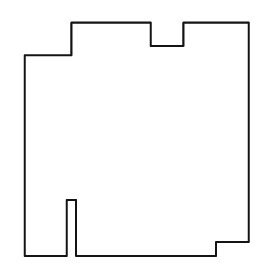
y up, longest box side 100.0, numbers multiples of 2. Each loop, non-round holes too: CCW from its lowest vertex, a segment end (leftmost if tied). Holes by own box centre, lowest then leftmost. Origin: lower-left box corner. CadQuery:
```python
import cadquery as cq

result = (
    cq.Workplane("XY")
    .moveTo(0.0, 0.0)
    .lineTo(18.0, 0.0)
    .lineTo(18.0, 24.0)
    .lineTo(22.0, 24.0)
    .lineTo(22.0, 0.0)
    .lineTo(82.0, 0.0)
    .lineTo(82.0, 6.0)
    .lineTo(96.0, 6.0)
    .lineTo(96.0, 100.0)
    .lineTo(68.0, 100.0)
    .lineTo(68.0, 90.0)
    .lineTo(54.0, 90.0)
    .lineTo(54.0, 100.0)
    .lineTo(20.0, 100.0)
    .lineTo(20.0, 86.0)
    .lineTo(0.0, 86.0)
    .close()
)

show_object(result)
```